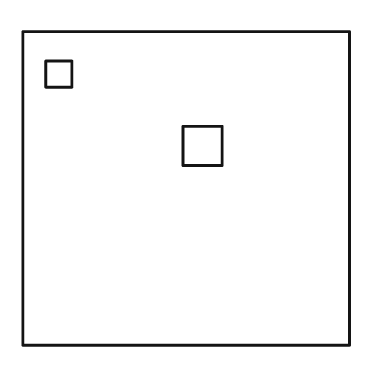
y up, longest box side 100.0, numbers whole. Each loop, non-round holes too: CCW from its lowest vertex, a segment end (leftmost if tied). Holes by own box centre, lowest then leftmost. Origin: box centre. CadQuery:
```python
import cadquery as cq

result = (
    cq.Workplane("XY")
    .moveTo(-50.0, -48.0)
    .lineTo(50.0, -48.0)
    .lineTo(50.0, 48.0)
    .lineTo(-50.0, 48.0)
    .close()
    .moveTo(-1.0, 7.0)
    .lineTo(11.0, 7.0)
    .lineTo(11.0, 19.0)
    .lineTo(-1.0, 19.0)
    .close()
    .moveTo(-43.0, 31.0)
    .lineTo(-35.0, 31.0)
    .lineTo(-35.0, 39.0)
    .lineTo(-43.0, 39.0)
    .close()
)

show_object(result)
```